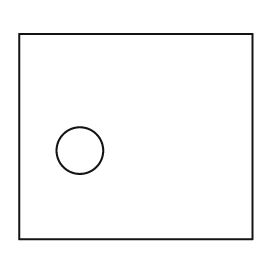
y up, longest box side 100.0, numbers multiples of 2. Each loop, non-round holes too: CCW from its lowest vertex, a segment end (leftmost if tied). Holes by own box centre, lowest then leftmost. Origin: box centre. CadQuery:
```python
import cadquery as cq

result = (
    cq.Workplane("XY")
    .moveTo(-50.0, -44.0)
    .lineTo(50.0, -44.0)
    .lineTo(50.0, 44.0)
    .lineTo(-50.0, 44.0)
    .close()
    .moveTo(-24.0, -6.0)
    .circle(10.0)
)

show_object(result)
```